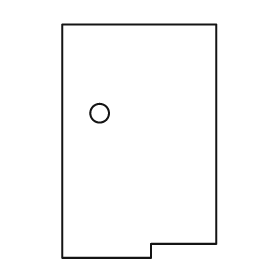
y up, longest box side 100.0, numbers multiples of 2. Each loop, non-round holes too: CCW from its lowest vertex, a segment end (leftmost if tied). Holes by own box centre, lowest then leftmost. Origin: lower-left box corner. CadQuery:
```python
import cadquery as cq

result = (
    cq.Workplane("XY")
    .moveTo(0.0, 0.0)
    .lineTo(38.0, 0.0)
    .lineTo(38.0, 6.0)
    .lineTo(66.0, 6.0)
    .lineTo(66.0, 100.0)
    .lineTo(0.0, 100.0)
    .close()
    .moveTo(16.0, 62.0)
    .circle(4.0)
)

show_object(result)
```